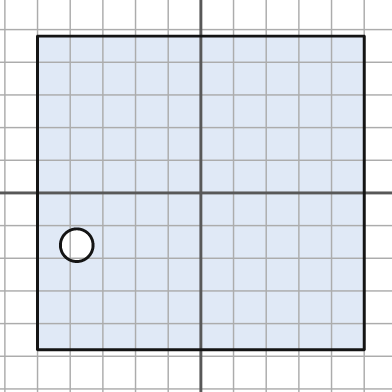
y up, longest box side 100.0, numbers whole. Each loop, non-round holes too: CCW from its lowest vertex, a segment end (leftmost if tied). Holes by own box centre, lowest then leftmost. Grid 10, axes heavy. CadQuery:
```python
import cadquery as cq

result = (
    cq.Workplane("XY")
    .moveTo(-50.0, -48.0)
    .lineTo(50.0, -48.0)
    .lineTo(50.0, 48.0)
    .lineTo(-50.0, 48.0)
    .close()
    .moveTo(-38.0, -16.0)
    .circle(5.0)
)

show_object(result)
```